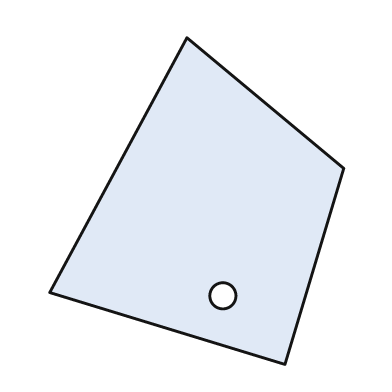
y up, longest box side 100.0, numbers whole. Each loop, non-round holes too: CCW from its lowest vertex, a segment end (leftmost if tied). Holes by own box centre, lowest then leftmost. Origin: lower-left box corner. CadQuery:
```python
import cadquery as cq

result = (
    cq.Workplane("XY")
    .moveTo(72.0, 0.0)
    .lineTo(90.0, 60.0)
    .lineTo(42.0, 100.0)
    .lineTo(0.0, 22.0)
    .close()
    .moveTo(53.0, 21.0)
    .circle(4.0)
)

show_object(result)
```